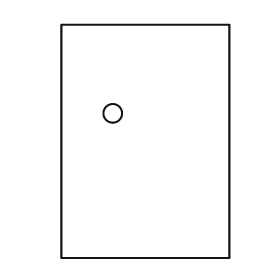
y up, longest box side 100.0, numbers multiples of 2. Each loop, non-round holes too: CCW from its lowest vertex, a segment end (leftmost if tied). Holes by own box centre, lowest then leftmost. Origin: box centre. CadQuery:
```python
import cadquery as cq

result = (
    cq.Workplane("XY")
    .moveTo(-36.0, -50.0)
    .lineTo(36.0, -50.0)
    .lineTo(36.0, 50.0)
    .lineTo(-36.0, 50.0)
    .close()
    .moveTo(-14.0, 12.0)
    .circle(4.0)
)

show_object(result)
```